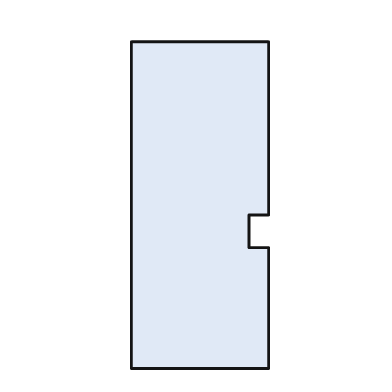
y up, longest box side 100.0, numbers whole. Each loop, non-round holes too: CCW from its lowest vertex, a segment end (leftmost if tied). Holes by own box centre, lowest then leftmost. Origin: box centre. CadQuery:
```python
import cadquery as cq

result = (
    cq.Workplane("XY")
    .moveTo(-21.0, -50.0)
    .lineTo(21.0, -50.0)
    .lineTo(21.0, -13.0)
    .lineTo(15.0, -13.0)
    .lineTo(15.0, -3.0)
    .lineTo(21.0, -3.0)
    .lineTo(21.0, 50.0)
    .lineTo(-21.0, 50.0)
    .close()
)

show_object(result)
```